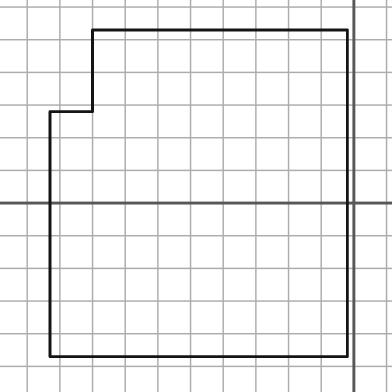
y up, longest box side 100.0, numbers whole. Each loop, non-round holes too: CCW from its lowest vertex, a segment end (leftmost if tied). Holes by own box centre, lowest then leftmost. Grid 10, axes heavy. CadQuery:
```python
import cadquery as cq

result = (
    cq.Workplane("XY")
    .moveTo(-93.0, -47.0)
    .lineTo(-2.0, -47.0)
    .lineTo(-2.0, 53.0)
    .lineTo(-80.0, 53.0)
    .lineTo(-80.0, 28.0)
    .lineTo(-93.0, 28.0)
    .close()
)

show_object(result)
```